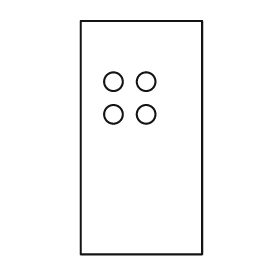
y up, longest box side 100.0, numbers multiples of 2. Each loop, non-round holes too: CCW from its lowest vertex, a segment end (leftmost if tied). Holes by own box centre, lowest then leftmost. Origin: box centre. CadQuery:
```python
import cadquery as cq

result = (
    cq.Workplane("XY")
    .moveTo(-26.0, -50.0)
    .lineTo(26.0, -50.0)
    .lineTo(26.0, 50.0)
    .lineTo(-26.0, 50.0)
    .close()
    .moveTo(-12.0, 10.0)
    .circle(4.0)
    .moveTo(2.0, 10.0)
    .circle(4.0)
    .moveTo(-12.0, 24.0)
    .circle(4.0)
    .moveTo(2.0, 24.0)
    .circle(4.0)
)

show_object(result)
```